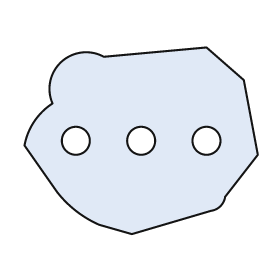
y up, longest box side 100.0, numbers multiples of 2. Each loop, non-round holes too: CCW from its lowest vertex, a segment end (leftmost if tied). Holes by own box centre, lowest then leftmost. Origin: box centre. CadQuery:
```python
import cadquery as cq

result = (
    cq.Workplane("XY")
    .moveTo(-4.0, -40.0)
    .lineTo(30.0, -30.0)
    .threePointArc((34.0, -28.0), (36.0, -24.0))
    .lineTo(50.0, -6.0)
    .lineTo(44.0, 26.0)
    .lineTo(28.0, 40.0)
    .lineTo(-16.0, 36.0)
    .threePointArc((-34.0, 34.0), (-38.0, 16.0))
    .threePointArc((-46.0, 8.0), (-50.0, -2.0))
    .lineTo(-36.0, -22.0)
    .threePointArc((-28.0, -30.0), (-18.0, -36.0))
    .close()
    .moveTo(-28.0, 0.0)
    .circle(6.0)
    .moveTo(0.0, 0.0)
    .circle(6.0)
    .moveTo(28.0, 0.0)
    .circle(6.0)
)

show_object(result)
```